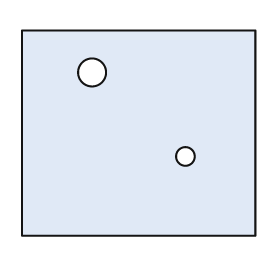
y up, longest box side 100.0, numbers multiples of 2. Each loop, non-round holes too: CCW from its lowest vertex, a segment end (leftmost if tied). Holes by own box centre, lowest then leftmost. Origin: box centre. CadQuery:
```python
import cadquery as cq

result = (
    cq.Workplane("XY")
    .moveTo(-50.0, -44.0)
    .lineTo(50.0, -44.0)
    .lineTo(50.0, 44.0)
    .lineTo(-50.0, 44.0)
    .close()
    .moveTo(20.0, -10.0)
    .circle(4.0)
    .moveTo(-20.0, 26.0)
    .circle(6.0)
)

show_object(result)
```